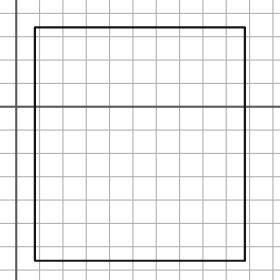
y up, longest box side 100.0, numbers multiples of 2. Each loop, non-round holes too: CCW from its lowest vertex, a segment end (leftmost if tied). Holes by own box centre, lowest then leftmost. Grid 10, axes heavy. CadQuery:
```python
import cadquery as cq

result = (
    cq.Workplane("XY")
    .moveTo(8.0, -66.0)
    .lineTo(98.0, -66.0)
    .lineTo(98.0, 34.0)
    .lineTo(8.0, 34.0)
    .close()
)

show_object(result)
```